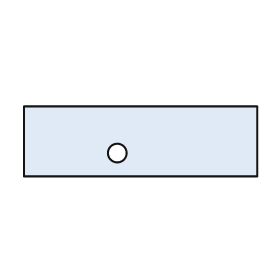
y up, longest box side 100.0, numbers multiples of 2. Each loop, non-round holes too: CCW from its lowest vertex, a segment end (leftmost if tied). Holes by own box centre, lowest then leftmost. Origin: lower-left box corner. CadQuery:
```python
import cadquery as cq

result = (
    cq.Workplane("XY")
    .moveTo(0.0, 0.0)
    .lineTo(100.0, 0.0)
    .lineTo(100.0, 30.0)
    .lineTo(0.0, 30.0)
    .close()
    .moveTo(40.0, 10.0)
    .circle(4.0)
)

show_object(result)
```